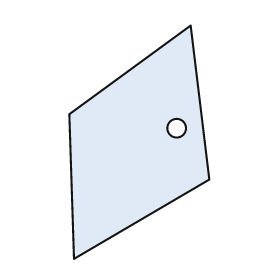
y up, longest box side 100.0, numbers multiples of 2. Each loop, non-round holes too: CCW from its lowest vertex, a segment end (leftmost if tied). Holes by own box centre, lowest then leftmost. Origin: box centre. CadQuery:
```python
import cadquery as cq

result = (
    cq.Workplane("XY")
    .moveTo(-28.0, -50.0)
    .lineTo(30.0, -16.0)
    .lineTo(22.0, 50.0)
    .lineTo(-30.0, 12.0)
    .close()
    .moveTo(16.0, 6.0)
    .circle(4.0)
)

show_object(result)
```